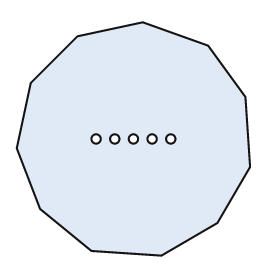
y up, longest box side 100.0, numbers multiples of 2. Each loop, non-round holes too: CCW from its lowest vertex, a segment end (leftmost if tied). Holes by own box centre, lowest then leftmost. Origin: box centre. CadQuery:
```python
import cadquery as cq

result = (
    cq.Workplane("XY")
    .moveTo(12.0, -50.0)
    .lineTo(36.0, -36.0)
    .lineTo(50.0, -12.0)
    .lineTo(48.0, 18.0)
    .lineTo(32.0, 40.0)
    .lineTo(4.0, 50.0)
    .lineTo(-24.0, 44.0)
    .lineTo(-44.0, 24.0)
    .lineTo(-50.0, -4.0)
    .lineTo(-40.0, -30.0)
    .lineTo(-18.0, -48.0)
    .close()
    .moveTo(-16.0, 0.0)
    .circle(2.0)
    .moveTo(-8.0, 0.0)
    .circle(2.0)
    .moveTo(0.0, 0.0)
    .circle(2.0)
    .moveTo(8.0, 0.0)
    .circle(2.0)
    .moveTo(16.0, 0.0)
    .circle(2.0)
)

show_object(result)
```